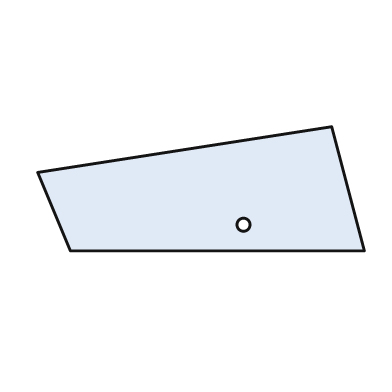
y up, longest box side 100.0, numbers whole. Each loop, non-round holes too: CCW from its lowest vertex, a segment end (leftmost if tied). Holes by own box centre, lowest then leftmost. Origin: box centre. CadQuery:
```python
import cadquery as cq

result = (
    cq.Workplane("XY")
    .moveTo(-40.0, -19.0)
    .lineTo(50.0, -19.0)
    .lineTo(40.0, 19.0)
    .lineTo(-50.0, 5.0)
    .close()
    .moveTo(13.0, -11.0)
    .circle(2.0)
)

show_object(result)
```